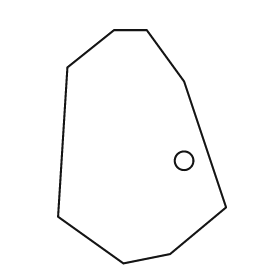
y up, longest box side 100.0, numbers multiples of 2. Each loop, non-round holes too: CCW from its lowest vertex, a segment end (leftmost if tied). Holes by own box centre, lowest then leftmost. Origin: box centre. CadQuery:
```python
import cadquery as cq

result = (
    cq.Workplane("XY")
    .moveTo(-8.0, -50.0)
    .lineTo(12.0, -46.0)
    .lineTo(36.0, -26.0)
    .lineTo(18.0, 28.0)
    .lineTo(2.0, 50.0)
    .lineTo(-12.0, 50.0)
    .lineTo(-32.0, 34.0)
    .lineTo(-36.0, -30.0)
    .close()
    .moveTo(18.0, -6.0)
    .circle(4.0)
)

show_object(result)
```